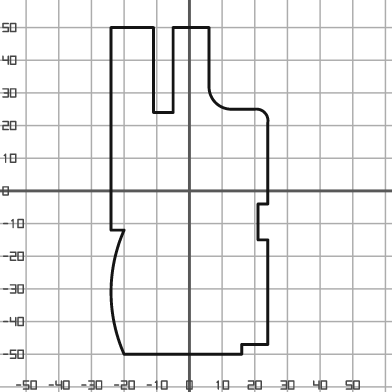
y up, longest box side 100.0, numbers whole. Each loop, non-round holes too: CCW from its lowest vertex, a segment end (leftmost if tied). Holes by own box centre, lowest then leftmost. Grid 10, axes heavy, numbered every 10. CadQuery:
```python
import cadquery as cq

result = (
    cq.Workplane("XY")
    .moveTo(-20.0, -50.0)
    .lineTo(16.0, -50.0)
    .lineTo(16.0, -47.0)
    .lineTo(24.0, -47.0)
    .lineTo(24.0, -15.0)
    .lineTo(21.0, -15.0)
    .lineTo(21.0, -4.0)
    .lineTo(24.0, -4.0)
    .lineTo(24.0, 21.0)
    .threePointArc((23.0, 24.0), (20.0, 25.0))
    .lineTo(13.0, 25.0)
    .threePointArc((8.0, 27.0), (6.0, 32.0))
    .lineTo(6.0, 50.0)
    .lineTo(-5.0, 50.0)
    .lineTo(-5.0, 24.0)
    .lineTo(-11.0, 24.0)
    .lineTo(-11.0, 50.0)
    .lineTo(-24.0, 50.0)
    .lineTo(-24.0, -12.0)
    .lineTo(-20.0, -12.0)
    .threePointArc((-24.0, -31.0), (-20.0, -50.0))
    .close()
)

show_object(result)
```